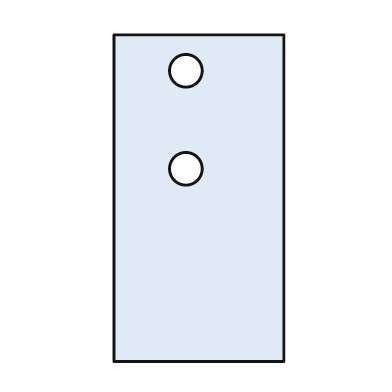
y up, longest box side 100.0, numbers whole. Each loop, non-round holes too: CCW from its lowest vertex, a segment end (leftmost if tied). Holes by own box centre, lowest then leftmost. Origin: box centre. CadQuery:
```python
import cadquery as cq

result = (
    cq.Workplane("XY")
    .moveTo(-26.0, -50.0)
    .lineTo(26.0, -50.0)
    .lineTo(26.0, 50.0)
    .lineTo(-26.0, 50.0)
    .close()
    .moveTo(-4.0, 9.0)
    .circle(5.0)
    .moveTo(-4.0, 39.0)
    .circle(5.0)
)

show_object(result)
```